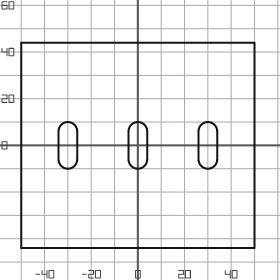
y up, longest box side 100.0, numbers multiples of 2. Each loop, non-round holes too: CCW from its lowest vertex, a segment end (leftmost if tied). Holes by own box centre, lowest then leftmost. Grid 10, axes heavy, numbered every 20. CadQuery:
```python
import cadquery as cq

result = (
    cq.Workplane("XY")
    .moveTo(-50.0, -44.0)
    .lineTo(50.0, -44.0)
    .lineTo(50.0, 44.0)
    .lineTo(-50.0, 44.0)
    .close()
    .moveTo(-34.0, -6.0)
    .threePointArc((-30.0, -10.0), (-26.0, -6.0))
    .lineTo(-26.0, 6.0)
    .threePointArc((-30.0, 10.0), (-34.0, 6.0))
    .close()
    .moveTo(-4.0, -6.0)
    .threePointArc((0.0, -10.0), (4.0, -6.0))
    .lineTo(4.0, 6.0)
    .threePointArc((0.0, 10.0), (-4.0, 6.0))
    .close()
    .moveTo(26.0, -6.0)
    .threePointArc((30.0, -10.0), (34.0, -6.0))
    .lineTo(34.0, 6.0)
    .threePointArc((30.0, 10.0), (26.0, 6.0))
    .close()
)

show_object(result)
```